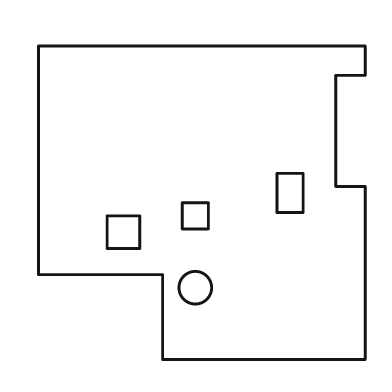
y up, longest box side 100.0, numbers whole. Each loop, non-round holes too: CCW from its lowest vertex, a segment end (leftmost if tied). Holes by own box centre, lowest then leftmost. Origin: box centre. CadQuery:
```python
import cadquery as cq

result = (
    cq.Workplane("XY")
    .moveTo(-12.0, -48.0)
    .lineTo(50.0, -48.0)
    .lineTo(50.0, 5.0)
    .lineTo(41.0, 5.0)
    .lineTo(41.0, 39.0)
    .lineTo(50.0, 39.0)
    .lineTo(50.0, 48.0)
    .lineTo(-50.0, 48.0)
    .lineTo(-50.0, -22.0)
    .lineTo(-12.0, -22.0)
    .close()
    .moveTo(-2.0, -26.0)
    .circle(5.0)
    .moveTo(-29.0, -14.0)
    .lineTo(-19.0, -14.0)
    .lineTo(-19.0, -4.0)
    .lineTo(-29.0, -4.0)
    .close()
    .moveTo(-6.0, -8.0)
    .lineTo(2.0, -8.0)
    .lineTo(2.0, 0.0)
    .lineTo(-6.0, 0.0)
    .close()
    .moveTo(23.0, -3.0)
    .lineTo(31.0, -3.0)
    .lineTo(31.0, 9.0)
    .lineTo(23.0, 9.0)
    .close()
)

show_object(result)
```